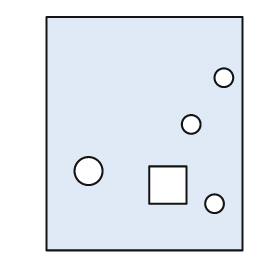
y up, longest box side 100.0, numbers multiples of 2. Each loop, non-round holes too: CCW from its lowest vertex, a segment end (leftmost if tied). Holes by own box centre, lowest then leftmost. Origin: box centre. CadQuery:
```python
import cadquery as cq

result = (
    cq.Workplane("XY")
    .moveTo(-42.0, -50.0)
    .lineTo(42.0, -50.0)
    .lineTo(42.0, 50.0)
    .lineTo(-42.0, 50.0)
    .close()
    .moveTo(30.0, -30.0)
    .circle(4.0)
    .moveTo(2.0, -30.0)
    .lineTo(18.0, -30.0)
    .lineTo(18.0, -14.0)
    .lineTo(2.0, -14.0)
    .close()
    .moveTo(-24.0, -16.0)
    .circle(6.0)
    .moveTo(20.0, 4.0)
    .circle(4.0)
    .moveTo(34.0, 24.0)
    .circle(4.0)
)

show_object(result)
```